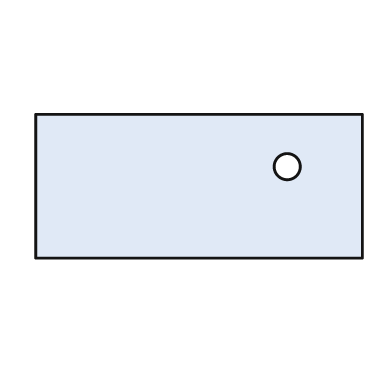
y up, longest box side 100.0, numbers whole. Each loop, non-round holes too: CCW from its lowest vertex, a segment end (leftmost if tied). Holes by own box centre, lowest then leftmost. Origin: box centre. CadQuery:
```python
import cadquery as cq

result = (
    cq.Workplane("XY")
    .moveTo(-50.0, -22.0)
    .lineTo(50.0, -22.0)
    .lineTo(50.0, 22.0)
    .lineTo(-50.0, 22.0)
    .close()
    .moveTo(27.0, 6.0)
    .circle(4.0)
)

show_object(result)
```